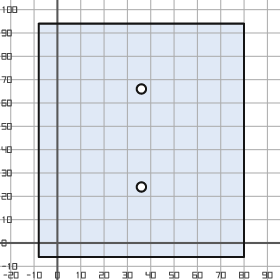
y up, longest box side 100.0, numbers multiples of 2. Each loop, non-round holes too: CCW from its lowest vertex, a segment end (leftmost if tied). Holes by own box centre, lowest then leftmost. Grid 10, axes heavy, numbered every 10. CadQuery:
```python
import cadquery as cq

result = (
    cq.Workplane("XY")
    .moveTo(-8.0, -6.0)
    .lineTo(80.0, -6.0)
    .lineTo(80.0, 94.0)
    .lineTo(-8.0, 94.0)
    .close()
    .moveTo(36.0, 24.0)
    .circle(2.0)
    .moveTo(36.0, 66.0)
    .circle(2.0)
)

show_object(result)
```